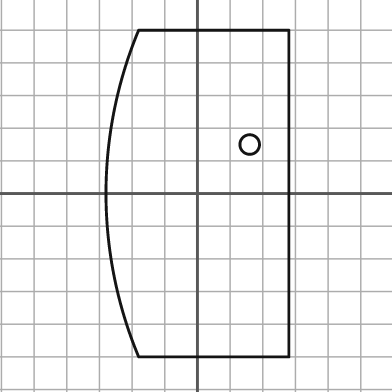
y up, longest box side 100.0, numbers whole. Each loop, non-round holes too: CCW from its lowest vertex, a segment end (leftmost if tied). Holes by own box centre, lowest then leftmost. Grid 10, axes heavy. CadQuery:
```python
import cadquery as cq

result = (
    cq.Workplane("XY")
    .moveTo(-18.0, -50.0)
    .lineTo(28.0, -50.0)
    .lineTo(28.0, 50.0)
    .lineTo(-18.0, 50.0)
    .threePointArc((-28.0, 0.0), (-18.0, -50.0))
    .close()
    .moveTo(16.0, 15.0)
    .circle(3.0)
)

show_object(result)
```